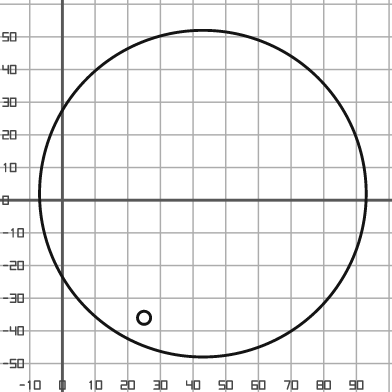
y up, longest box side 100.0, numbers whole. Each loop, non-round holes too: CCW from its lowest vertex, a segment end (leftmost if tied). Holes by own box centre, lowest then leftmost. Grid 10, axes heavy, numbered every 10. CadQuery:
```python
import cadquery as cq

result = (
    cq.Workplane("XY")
    .moveTo(43.0, 2.0)
    .circle(50.0)
    .moveTo(25.0, -36.0)
    .circle(2.0)
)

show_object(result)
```